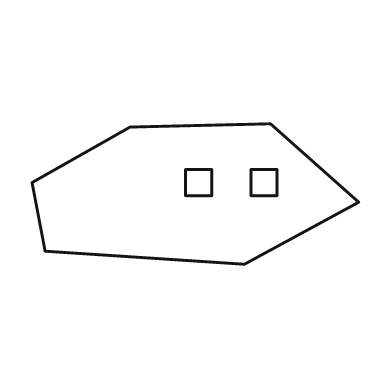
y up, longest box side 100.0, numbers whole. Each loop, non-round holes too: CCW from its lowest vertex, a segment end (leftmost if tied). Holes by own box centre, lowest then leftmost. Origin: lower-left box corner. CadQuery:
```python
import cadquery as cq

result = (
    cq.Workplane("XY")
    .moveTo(65.0, 0.0)
    .lineTo(100.0, 19.0)
    .lineTo(73.0, 43.0)
    .lineTo(30.0, 42.0)
    .lineTo(0.0, 25.0)
    .lineTo(4.0, 4.0)
    .close()
    .moveTo(47.0, 21.0)
    .lineTo(55.0, 21.0)
    .lineTo(55.0, 29.0)
    .lineTo(47.0, 29.0)
    .close()
    .moveTo(67.0, 21.0)
    .lineTo(75.0, 21.0)
    .lineTo(75.0, 29.0)
    .lineTo(67.0, 29.0)
    .close()
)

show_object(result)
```